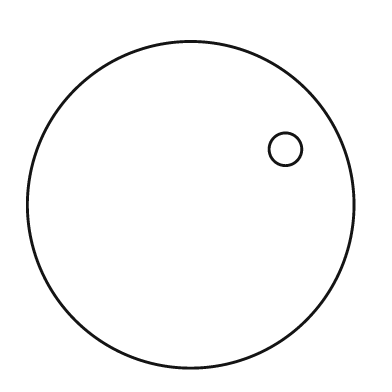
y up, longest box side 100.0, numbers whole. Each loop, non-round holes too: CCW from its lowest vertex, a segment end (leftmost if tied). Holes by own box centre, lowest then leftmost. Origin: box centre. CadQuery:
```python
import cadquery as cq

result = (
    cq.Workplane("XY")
    .moveTo(0.0, 0.0)
    .circle(50.0)
    .moveTo(29.0, 17.0)
    .circle(5.0)
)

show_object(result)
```